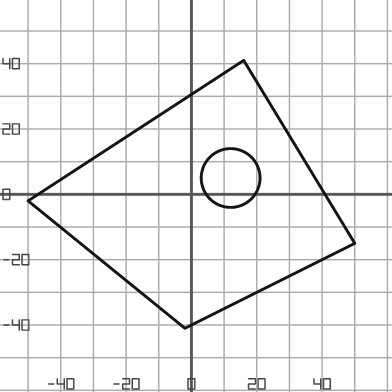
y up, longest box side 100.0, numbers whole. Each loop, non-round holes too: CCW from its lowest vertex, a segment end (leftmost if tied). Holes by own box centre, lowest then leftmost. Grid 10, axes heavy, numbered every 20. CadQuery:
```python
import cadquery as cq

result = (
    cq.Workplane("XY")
    .moveTo(-2.0, -41.0)
    .lineTo(50.0, -15.0)
    .lineTo(16.0, 41.0)
    .lineTo(-50.0, -2.0)
    .close()
    .moveTo(12.0, 5.0)
    .circle(9.0)
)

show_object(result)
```